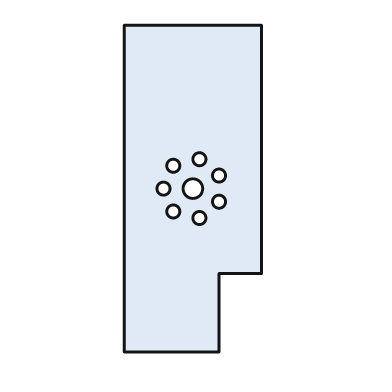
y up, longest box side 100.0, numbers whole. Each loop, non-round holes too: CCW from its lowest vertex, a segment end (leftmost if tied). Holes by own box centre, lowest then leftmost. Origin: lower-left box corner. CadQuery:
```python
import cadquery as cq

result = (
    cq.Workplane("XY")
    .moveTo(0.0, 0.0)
    .lineTo(29.0, 0.0)
    .lineTo(29.0, 24.0)
    .lineTo(42.0, 24.0)
    .lineTo(42.0, 100.0)
    .lineTo(0.0, 100.0)
    .close()
    .moveTo(23.0, 41.0)
    .circle(2.0)
    .moveTo(15.0, 43.0)
    .circle(2.0)
    .moveTo(29.0, 46.0)
    .circle(2.0)
    .moveTo(12.0, 50.0)
    .circle(2.0)
    .moveTo(21.0, 50.0)
    .circle(3.0)
    .moveTo(29.0, 54.0)
    .circle(2.0)
    .moveTo(15.0, 57.0)
    .circle(2.0)
    .moveTo(23.0, 59.0)
    .circle(2.0)
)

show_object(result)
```